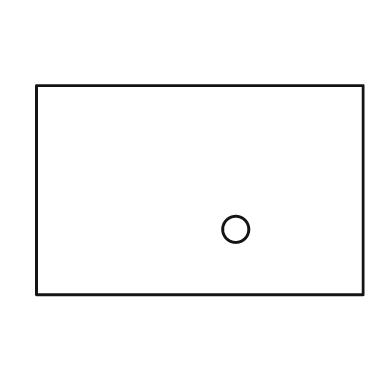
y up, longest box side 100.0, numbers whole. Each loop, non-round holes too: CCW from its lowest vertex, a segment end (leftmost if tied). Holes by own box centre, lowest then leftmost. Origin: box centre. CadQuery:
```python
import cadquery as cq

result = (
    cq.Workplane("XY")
    .moveTo(-50.0, -32.0)
    .lineTo(50.0, -32.0)
    .lineTo(50.0, 32.0)
    .lineTo(-50.0, 32.0)
    .close()
    .moveTo(11.0, -12.0)
    .circle(4.0)
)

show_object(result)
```